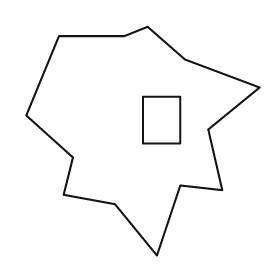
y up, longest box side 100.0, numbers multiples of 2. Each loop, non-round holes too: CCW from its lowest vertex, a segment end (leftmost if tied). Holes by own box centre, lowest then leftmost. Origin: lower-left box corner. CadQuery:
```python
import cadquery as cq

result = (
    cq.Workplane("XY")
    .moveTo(56.0, 0.0)
    .lineTo(66.0, 30.0)
    .lineTo(84.0, 28.0)
    .lineTo(78.0, 54.0)
    .lineTo(100.0, 72.0)
    .lineTo(68.0, 84.0)
    .lineTo(52.0, 98.0)
    .lineTo(42.0, 94.0)
    .lineTo(14.0, 94.0)
    .lineTo(0.0, 60.0)
    .lineTo(20.0, 42.0)
    .lineTo(16.0, 26.0)
    .lineTo(38.0, 22.0)
    .close()
    .moveTo(50.0, 48.0)
    .lineTo(66.0, 48.0)
    .lineTo(66.0, 68.0)
    .lineTo(50.0, 68.0)
    .close()
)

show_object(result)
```